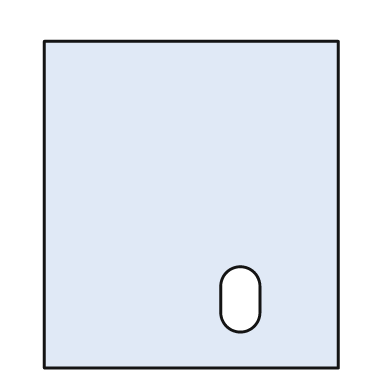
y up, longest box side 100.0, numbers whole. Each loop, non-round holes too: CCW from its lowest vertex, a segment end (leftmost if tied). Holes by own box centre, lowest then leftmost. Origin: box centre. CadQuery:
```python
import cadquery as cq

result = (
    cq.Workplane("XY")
    .moveTo(-45.0, -50.0)
    .lineTo(45.0, -50.0)
    .lineTo(45.0, 50.0)
    .lineTo(-45.0, 50.0)
    .close()
    .moveTo(9.0, -33.0)
    .threePointArc((15.0, -39.0), (21.0, -33.0))
    .lineTo(21.0, -25.0)
    .threePointArc((15.0, -19.0), (9.0, -25.0))
    .close()
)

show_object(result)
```